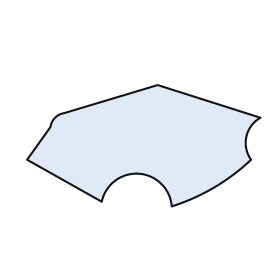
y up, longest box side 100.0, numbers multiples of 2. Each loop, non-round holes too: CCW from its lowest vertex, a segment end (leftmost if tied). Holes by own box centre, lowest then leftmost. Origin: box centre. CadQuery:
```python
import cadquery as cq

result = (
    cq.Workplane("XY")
    .moveTo(12.0, -26.0)
    .threePointArc((30.0, -18.0), (46.0, -6.0))
    .threePointArc((44.0, 4.0), (50.0, 12.0))
    .lineTo(6.0, 26.0)
    .lineTo(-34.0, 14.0)
    .threePointArc((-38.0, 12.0), (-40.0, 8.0))
    .lineTo(-50.0, -6.0)
    .lineTo(-18.0, -24.0)
    .threePointArc((-2.0, -12.0), (12.0, -26.0))
    .close()
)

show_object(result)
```